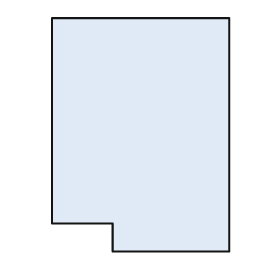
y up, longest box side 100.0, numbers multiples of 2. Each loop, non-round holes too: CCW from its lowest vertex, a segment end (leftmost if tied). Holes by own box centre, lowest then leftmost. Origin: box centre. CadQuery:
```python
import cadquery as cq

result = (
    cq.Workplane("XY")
    .moveTo(-12.0, -50.0)
    .lineTo(38.0, -50.0)
    .lineTo(38.0, 50.0)
    .lineTo(-38.0, 50.0)
    .lineTo(-38.0, -38.0)
    .lineTo(-12.0, -38.0)
    .close()
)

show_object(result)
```